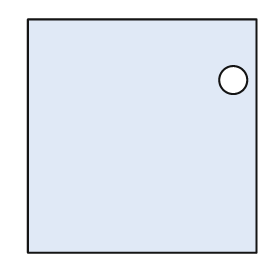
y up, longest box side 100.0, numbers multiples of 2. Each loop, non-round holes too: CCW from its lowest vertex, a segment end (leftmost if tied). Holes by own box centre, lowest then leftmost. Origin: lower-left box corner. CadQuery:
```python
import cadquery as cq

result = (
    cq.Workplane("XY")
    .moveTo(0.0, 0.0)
    .lineTo(98.0, 0.0)
    .lineTo(98.0, 100.0)
    .lineTo(0.0, 100.0)
    .close()
    .moveTo(88.0, 74.0)
    .circle(6.0)
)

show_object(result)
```